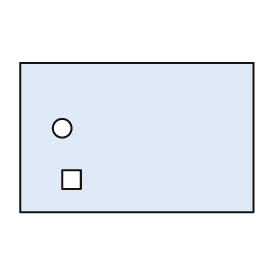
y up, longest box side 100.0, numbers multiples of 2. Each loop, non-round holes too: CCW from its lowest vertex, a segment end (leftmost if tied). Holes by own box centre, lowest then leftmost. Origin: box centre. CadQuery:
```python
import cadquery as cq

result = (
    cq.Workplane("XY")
    .moveTo(-50.0, -32.0)
    .lineTo(50.0, -32.0)
    .lineTo(50.0, 32.0)
    .lineTo(-50.0, 32.0)
    .close()
    .moveTo(-32.0, -22.0)
    .lineTo(-24.0, -22.0)
    .lineTo(-24.0, -14.0)
    .lineTo(-32.0, -14.0)
    .close()
    .moveTo(-32.0, 4.0)
    .circle(4.0)
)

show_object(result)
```